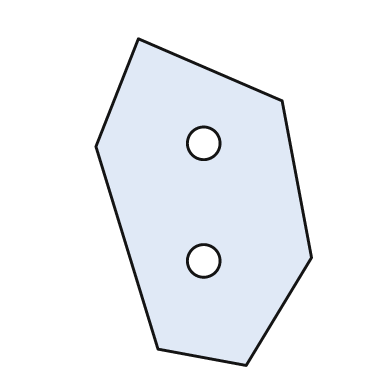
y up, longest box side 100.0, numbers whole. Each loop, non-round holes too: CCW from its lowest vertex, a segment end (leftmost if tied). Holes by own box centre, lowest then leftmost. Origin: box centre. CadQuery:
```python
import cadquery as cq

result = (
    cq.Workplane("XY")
    .moveTo(13.0, -50.0)
    .lineTo(33.0, -17.0)
    .lineTo(24.0, 31.0)
    .lineTo(-20.0, 50.0)
    .lineTo(-33.0, 17.0)
    .lineTo(-14.0, -45.0)
    .close()
    .moveTo(0.0, -18.0)
    .circle(5.0)
    .moveTo(0.0, 18.0)
    .circle(5.0)
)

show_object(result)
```